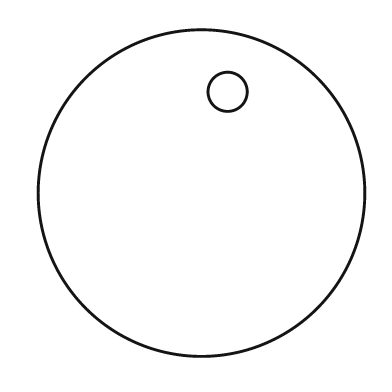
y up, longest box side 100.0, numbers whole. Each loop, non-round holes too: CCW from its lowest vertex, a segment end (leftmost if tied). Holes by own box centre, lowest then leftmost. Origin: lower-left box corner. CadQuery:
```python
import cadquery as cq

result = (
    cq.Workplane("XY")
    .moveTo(50.0, 50.0)
    .circle(50.0)
    .moveTo(58.0, 81.0)
    .circle(6.0)
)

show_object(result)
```